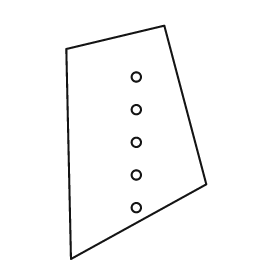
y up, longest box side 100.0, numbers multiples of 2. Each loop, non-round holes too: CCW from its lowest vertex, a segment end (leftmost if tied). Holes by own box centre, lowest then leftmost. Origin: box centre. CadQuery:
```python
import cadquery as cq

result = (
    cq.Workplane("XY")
    .moveTo(-28.0, -50.0)
    .lineTo(30.0, -18.0)
    .lineTo(12.0, 50.0)
    .lineTo(-30.0, 40.0)
    .close()
    .moveTo(0.0, -28.0)
    .circle(2.0)
    .moveTo(0.0, -14.0)
    .circle(2.0)
    .moveTo(0.0, 0.0)
    .circle(2.0)
    .moveTo(0.0, 14.0)
    .circle(2.0)
    .moveTo(0.0, 28.0)
    .circle(2.0)
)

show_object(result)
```